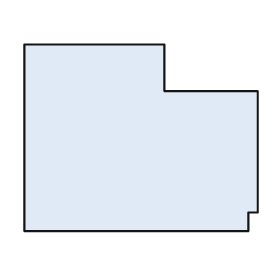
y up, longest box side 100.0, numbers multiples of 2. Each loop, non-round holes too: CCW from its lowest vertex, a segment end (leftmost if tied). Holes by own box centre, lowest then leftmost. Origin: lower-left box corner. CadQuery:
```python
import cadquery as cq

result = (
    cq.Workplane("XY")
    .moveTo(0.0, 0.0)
    .lineTo(96.0, 0.0)
    .lineTo(96.0, 8.0)
    .lineTo(100.0, 8.0)
    .lineTo(100.0, 60.0)
    .lineTo(60.0, 60.0)
    .lineTo(60.0, 80.0)
    .lineTo(0.0, 80.0)
    .close()
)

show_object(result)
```